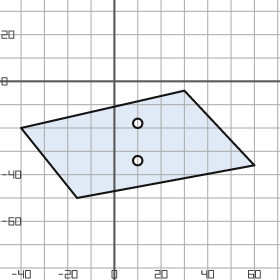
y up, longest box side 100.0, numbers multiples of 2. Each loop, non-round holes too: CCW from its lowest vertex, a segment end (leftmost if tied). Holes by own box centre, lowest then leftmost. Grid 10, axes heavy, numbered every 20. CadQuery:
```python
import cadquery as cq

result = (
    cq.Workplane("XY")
    .moveTo(-16.0, -50.0)
    .lineTo(60.0, -36.0)
    .lineTo(30.0, -4.0)
    .lineTo(-40.0, -20.0)
    .close()
    .moveTo(10.0, -34.0)
    .circle(2.0)
    .moveTo(10.0, -18.0)
    .circle(2.0)
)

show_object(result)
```